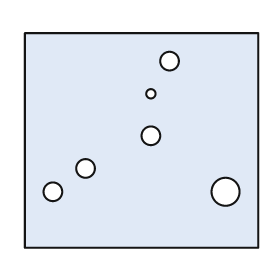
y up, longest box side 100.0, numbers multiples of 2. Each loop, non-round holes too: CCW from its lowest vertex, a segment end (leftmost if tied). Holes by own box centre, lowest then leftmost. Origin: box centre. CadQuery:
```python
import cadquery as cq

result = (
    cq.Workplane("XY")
    .moveTo(-50.0, -46.0)
    .lineTo(50.0, -46.0)
    .lineTo(50.0, 46.0)
    .lineTo(-50.0, 46.0)
    .close()
    .moveTo(-38.0, -22.0)
    .circle(4.0)
    .moveTo(36.0, -22.0)
    .circle(6.0)
    .moveTo(-24.0, -12.0)
    .circle(4.0)
    .moveTo(4.0, 2.0)
    .circle(4.0)
    .moveTo(4.0, 20.0)
    .circle(2.0)
    .moveTo(12.0, 34.0)
    .circle(4.0)
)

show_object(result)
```